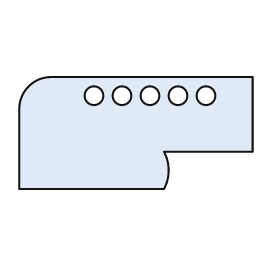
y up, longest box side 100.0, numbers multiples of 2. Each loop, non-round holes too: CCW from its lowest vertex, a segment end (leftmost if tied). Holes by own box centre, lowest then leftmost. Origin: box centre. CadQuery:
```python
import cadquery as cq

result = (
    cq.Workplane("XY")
    .moveTo(-50.0, -24.0)
    .lineTo(12.0, -24.0)
    .threePointArc((14.0, -16.0), (12.0, -8.0))
    .lineTo(50.0, -8.0)
    .lineTo(50.0, 24.0)
    .lineTo(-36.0, 24.0)
    .threePointArc((-46.0, 20.0), (-50.0, 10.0))
    .close()
    .moveTo(-18.0, 16.0)
    .circle(4.0)
    .moveTo(-6.0, 16.0)
    .circle(4.0)
    .moveTo(6.0, 16.0)
    .circle(4.0)
    .moveTo(18.0, 16.0)
    .circle(4.0)
    .moveTo(30.0, 16.0)
    .circle(4.0)
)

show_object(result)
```